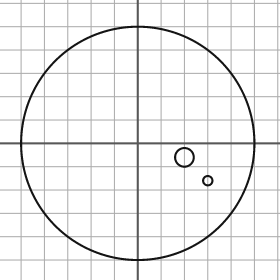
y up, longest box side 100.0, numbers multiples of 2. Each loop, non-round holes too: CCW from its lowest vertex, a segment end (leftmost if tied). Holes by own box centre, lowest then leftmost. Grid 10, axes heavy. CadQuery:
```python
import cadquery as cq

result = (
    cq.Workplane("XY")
    .moveTo(0.0, 0.0)
    .circle(50.0)
    .moveTo(30.0, -16.0)
    .circle(2.0)
    .moveTo(20.0, -6.0)
    .circle(4.0)
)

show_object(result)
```